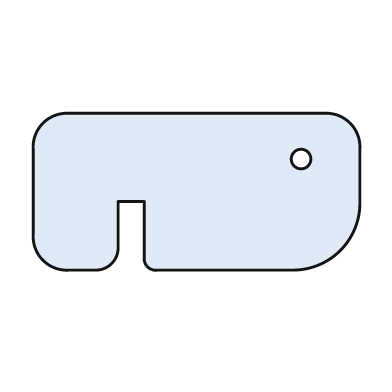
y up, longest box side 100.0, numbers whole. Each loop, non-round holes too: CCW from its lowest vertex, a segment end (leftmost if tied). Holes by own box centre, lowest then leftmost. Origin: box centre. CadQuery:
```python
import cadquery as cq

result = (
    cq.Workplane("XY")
    .moveTo(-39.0, -24.0)
    .lineTo(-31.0, -24.0)
    .threePointArc((-26.0, -22.0), (-24.0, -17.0))
    .lineTo(-24.0, -3.0)
    .lineTo(-16.0, -3.0)
    .lineTo(-16.0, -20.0)
    .threePointArc((-15.0, -23.0), (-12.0, -24.0))
    .lineTo(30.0, -24.0)
    .threePointArc((44.0, -18.0), (50.0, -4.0))
    .lineTo(50.0, 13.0)
    .threePointArc((47.0, 21.0), (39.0, 24.0))
    .lineTo(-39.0, 24.0)
    .threePointArc((-47.0, 21.0), (-50.0, 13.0))
    .lineTo(-50.0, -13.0)
    .threePointArc((-47.0, -21.0), (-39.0, -24.0))
    .close()
    .moveTo(32.0, 10.0)
    .circle(3.0)
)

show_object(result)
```